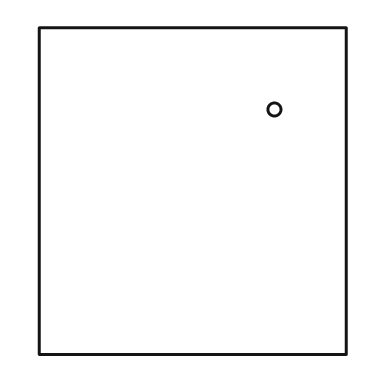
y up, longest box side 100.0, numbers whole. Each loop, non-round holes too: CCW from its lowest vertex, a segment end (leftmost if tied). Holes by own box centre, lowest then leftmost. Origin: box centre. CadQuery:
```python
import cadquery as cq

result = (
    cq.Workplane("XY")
    .moveTo(-47.0, -50.0)
    .lineTo(47.0, -50.0)
    .lineTo(47.0, 50.0)
    .lineTo(-47.0, 50.0)
    .close()
    .moveTo(25.0, 25.0)
    .circle(2.0)
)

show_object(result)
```